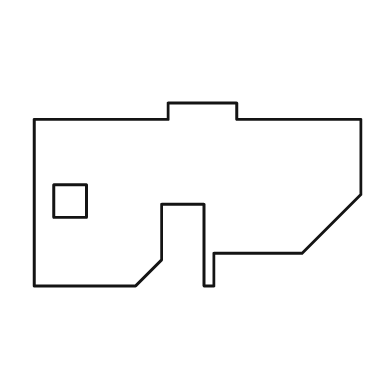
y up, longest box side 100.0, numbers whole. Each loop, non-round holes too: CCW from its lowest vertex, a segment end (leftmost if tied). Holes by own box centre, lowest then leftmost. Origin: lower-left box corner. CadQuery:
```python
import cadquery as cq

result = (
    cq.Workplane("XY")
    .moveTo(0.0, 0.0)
    .lineTo(31.0, 0.0)
    .lineTo(39.0, 8.0)
    .lineTo(39.0, 25.0)
    .lineTo(52.0, 25.0)
    .lineTo(52.0, 0.0)
    .lineTo(55.0, 0.0)
    .lineTo(55.0, 10.0)
    .lineTo(82.0, 10.0)
    .lineTo(100.0, 28.0)
    .lineTo(100.0, 51.0)
    .lineTo(62.0, 51.0)
    .lineTo(62.0, 56.0)
    .lineTo(41.0, 56.0)
    .lineTo(41.0, 51.0)
    .lineTo(0.0, 51.0)
    .close()
    .moveTo(6.0, 21.0)
    .lineTo(16.0, 21.0)
    .lineTo(16.0, 31.0)
    .lineTo(6.0, 31.0)
    .close()
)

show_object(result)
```